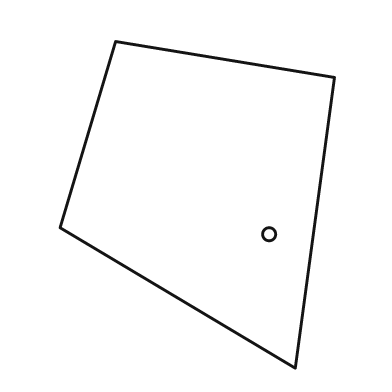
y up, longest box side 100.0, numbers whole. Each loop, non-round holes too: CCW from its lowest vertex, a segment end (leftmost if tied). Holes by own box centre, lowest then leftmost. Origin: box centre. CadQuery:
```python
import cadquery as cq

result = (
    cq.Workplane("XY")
    .moveTo(30.0, -50.0)
    .lineTo(42.0, 39.0)
    .lineTo(-25.0, 50.0)
    .lineTo(-42.0, -7.0)
    .close()
    .moveTo(22.0, -9.0)
    .circle(2.0)
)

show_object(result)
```